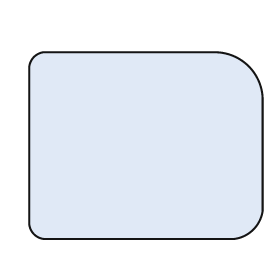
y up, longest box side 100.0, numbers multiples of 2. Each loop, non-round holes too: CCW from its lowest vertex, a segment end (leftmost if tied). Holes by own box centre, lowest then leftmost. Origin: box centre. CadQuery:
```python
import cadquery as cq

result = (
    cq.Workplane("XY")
    .moveTo(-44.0, -40.0)
    .lineTo(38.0, -40.0)
    .threePointArc((46.0, -36.0), (50.0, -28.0))
    .lineTo(50.0, 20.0)
    .threePointArc((44.0, 34.0), (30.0, 40.0))
    .lineTo(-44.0, 40.0)
    .threePointArc((-48.0, 38.0), (-50.0, 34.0))
    .lineTo(-50.0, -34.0)
    .threePointArc((-48.0, -38.0), (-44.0, -40.0))
    .close()
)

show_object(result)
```